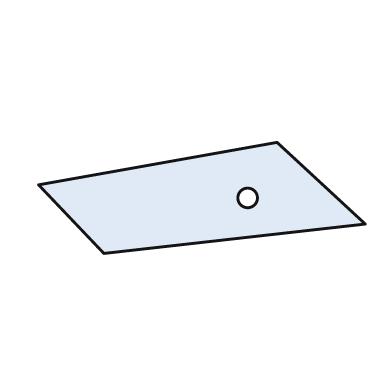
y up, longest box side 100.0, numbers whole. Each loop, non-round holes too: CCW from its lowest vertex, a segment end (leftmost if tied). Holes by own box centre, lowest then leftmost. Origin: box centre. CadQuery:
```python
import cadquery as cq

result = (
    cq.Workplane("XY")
    .moveTo(-30.0, -17.0)
    .lineTo(50.0, -8.0)
    .lineTo(23.0, 17.0)
    .lineTo(-50.0, 4.0)
    .close()
    .moveTo(14.0, 0.0)
    .circle(3.0)
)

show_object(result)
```